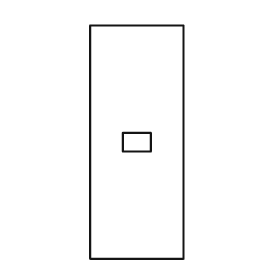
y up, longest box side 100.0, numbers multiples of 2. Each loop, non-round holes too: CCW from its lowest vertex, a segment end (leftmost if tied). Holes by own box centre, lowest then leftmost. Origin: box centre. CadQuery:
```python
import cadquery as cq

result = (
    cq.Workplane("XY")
    .moveTo(-20.0, -50.0)
    .lineTo(20.0, -50.0)
    .lineTo(20.0, 50.0)
    .lineTo(-20.0, 50.0)
    .close()
    .moveTo(-6.0, -4.0)
    .lineTo(6.0, -4.0)
    .lineTo(6.0, 4.0)
    .lineTo(-6.0, 4.0)
    .close()
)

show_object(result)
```